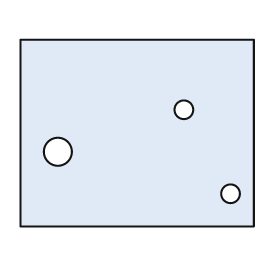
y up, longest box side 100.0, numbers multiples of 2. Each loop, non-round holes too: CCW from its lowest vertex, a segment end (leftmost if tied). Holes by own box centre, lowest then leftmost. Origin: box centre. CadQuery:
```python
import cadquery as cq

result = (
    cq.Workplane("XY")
    .moveTo(-50.0, -40.0)
    .lineTo(50.0, -40.0)
    .lineTo(50.0, 40.0)
    .lineTo(-50.0, 40.0)
    .close()
    .moveTo(40.0, -26.0)
    .circle(4.0)
    .moveTo(-34.0, -8.0)
    .circle(6.0)
    .moveTo(20.0, 10.0)
    .circle(4.0)
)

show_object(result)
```